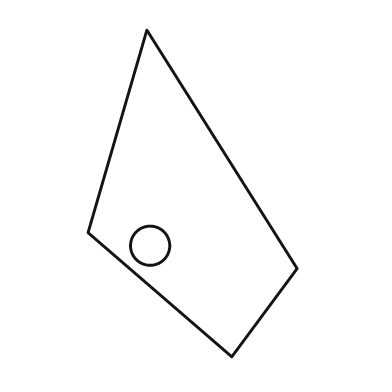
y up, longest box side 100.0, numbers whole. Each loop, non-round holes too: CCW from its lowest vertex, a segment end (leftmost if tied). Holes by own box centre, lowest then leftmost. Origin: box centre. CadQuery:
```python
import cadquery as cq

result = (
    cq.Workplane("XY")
    .moveTo(12.0, -50.0)
    .lineTo(32.0, -23.0)
    .lineTo(-14.0, 50.0)
    .lineTo(-32.0, -12.0)
    .close()
    .moveTo(-13.0, -16.0)
    .circle(6.0)
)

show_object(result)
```